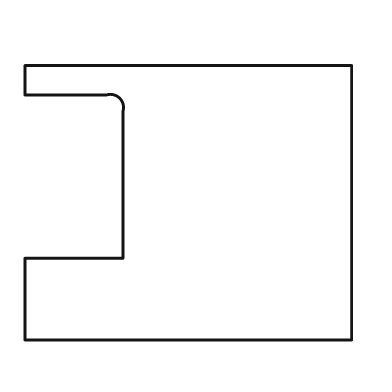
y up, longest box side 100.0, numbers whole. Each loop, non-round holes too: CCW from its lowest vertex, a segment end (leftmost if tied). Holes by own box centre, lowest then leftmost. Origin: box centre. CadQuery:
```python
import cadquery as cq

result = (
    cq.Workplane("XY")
    .moveTo(-50.0, -42.0)
    .lineTo(50.0, -42.0)
    .lineTo(50.0, 42.0)
    .lineTo(-50.0, 42.0)
    .lineTo(-50.0, 33.0)
    .lineTo(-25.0, 33.0)
    .threePointArc((-21.0, 32.0), (-20.0, 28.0))
    .lineTo(-20.0, -17.0)
    .lineTo(-50.0, -17.0)
    .close()
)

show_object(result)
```